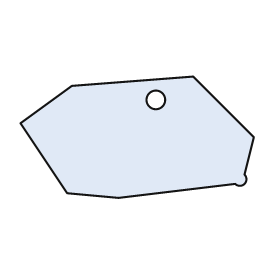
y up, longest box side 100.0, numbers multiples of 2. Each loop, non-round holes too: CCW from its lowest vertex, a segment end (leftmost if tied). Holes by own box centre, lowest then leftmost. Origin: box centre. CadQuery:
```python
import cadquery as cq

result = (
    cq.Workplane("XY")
    .moveTo(-8.0, -26.0)
    .lineTo(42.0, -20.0)
    .threePointArc((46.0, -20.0), (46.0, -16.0))
    .lineTo(50.0, 0.0)
    .lineTo(24.0, 26.0)
    .lineTo(-28.0, 22.0)
    .lineTo(-50.0, 6.0)
    .lineTo(-30.0, -24.0)
    .close()
    .moveTo(8.0, 16.0)
    .circle(4.0)
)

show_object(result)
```